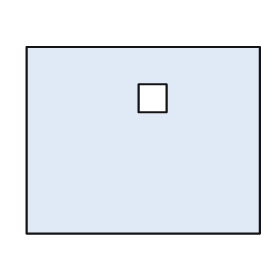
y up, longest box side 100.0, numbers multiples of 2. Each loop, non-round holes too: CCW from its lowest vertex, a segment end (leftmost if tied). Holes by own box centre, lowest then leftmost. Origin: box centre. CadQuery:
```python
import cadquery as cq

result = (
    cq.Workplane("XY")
    .moveTo(-50.0, -40.0)
    .lineTo(50.0, -40.0)
    .lineTo(50.0, 40.0)
    .lineTo(-50.0, 40.0)
    .close()
    .moveTo(-2.0, 12.0)
    .lineTo(10.0, 12.0)
    .lineTo(10.0, 24.0)
    .lineTo(-2.0, 24.0)
    .close()
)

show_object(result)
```